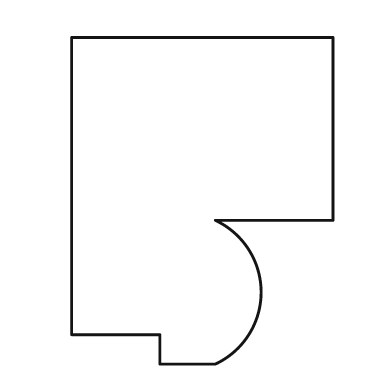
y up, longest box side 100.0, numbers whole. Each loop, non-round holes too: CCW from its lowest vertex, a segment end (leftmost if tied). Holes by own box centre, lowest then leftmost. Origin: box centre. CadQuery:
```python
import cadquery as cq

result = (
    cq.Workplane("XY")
    .moveTo(-13.0, -50.0)
    .lineTo(4.0, -50.0)
    .threePointArc((18.0, -28.0), (4.0, -6.0))
    .lineTo(40.0, -6.0)
    .lineTo(40.0, 50.0)
    .lineTo(-40.0, 50.0)
    .lineTo(-40.0, -41.0)
    .lineTo(-13.0, -41.0)
    .close()
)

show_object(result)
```